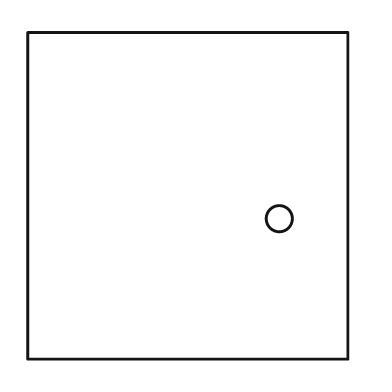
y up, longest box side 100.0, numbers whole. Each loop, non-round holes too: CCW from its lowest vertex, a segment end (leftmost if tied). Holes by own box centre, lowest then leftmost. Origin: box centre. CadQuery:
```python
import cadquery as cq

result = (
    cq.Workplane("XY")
    .moveTo(-49.0, -50.0)
    .lineTo(49.0, -50.0)
    .lineTo(49.0, 50.0)
    .lineTo(-49.0, 50.0)
    .close()
    .moveTo(28.0, -7.0)
    .circle(4.0)
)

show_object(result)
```